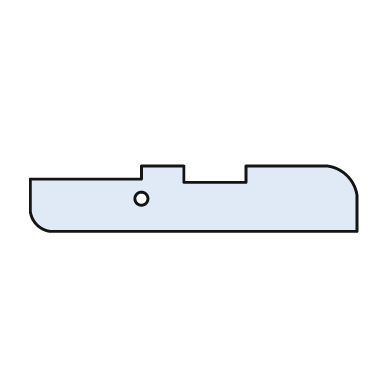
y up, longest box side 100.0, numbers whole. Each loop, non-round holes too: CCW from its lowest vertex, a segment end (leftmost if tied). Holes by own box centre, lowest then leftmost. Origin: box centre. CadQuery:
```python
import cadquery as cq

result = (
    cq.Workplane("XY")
    .moveTo(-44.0, -10.0)
    .lineTo(50.0, -10.0)
    .lineTo(50.0, 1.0)
    .threePointArc((47.0, 7.0), (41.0, 10.0))
    .lineTo(16.0, 10.0)
    .lineTo(16.0, 5.0)
    .lineTo(-3.0, 5.0)
    .lineTo(-3.0, 10.0)
    .lineTo(-16.0, 10.0)
    .lineTo(-16.0, 6.0)
    .lineTo(-50.0, 6.0)
    .lineTo(-50.0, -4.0)
    .threePointArc((-48.0, -8.0), (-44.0, -10.0))
    .close()
    .moveTo(-16.0, 0.0)
    .circle(2.0)
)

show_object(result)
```